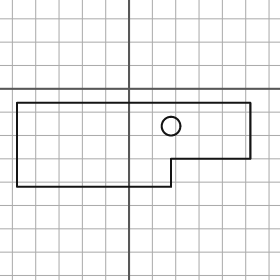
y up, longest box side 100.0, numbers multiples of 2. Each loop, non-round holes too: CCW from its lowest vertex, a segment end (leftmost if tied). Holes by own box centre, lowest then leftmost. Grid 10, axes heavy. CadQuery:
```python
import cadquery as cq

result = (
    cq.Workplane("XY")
    .moveTo(-48.0, -42.0)
    .lineTo(18.0, -42.0)
    .lineTo(18.0, -30.0)
    .lineTo(52.0, -30.0)
    .lineTo(52.0, -6.0)
    .lineTo(-48.0, -6.0)
    .close()
    .moveTo(18.0, -16.0)
    .circle(4.0)
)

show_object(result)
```